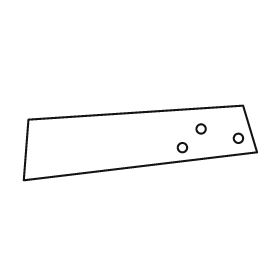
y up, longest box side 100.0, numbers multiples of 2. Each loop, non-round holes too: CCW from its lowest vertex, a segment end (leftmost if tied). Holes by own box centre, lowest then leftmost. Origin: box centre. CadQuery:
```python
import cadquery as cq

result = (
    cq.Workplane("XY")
    .moveTo(-50.0, -16.0)
    .lineTo(50.0, -4.0)
    .lineTo(44.0, 16.0)
    .lineTo(-48.0, 10.0)
    .close()
    .moveTo(18.0, -2.0)
    .circle(2.0)
    .moveTo(42.0, 2.0)
    .circle(2.0)
    .moveTo(26.0, 6.0)
    .circle(2.0)
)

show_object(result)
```